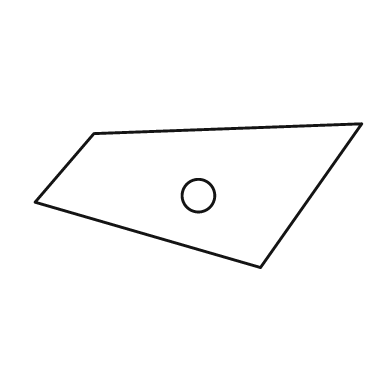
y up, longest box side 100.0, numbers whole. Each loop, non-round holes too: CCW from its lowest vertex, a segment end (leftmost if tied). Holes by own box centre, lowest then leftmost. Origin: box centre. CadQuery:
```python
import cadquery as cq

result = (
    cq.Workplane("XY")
    .moveTo(19.0, -22.0)
    .lineTo(50.0, 22.0)
    .lineTo(-32.0, 19.0)
    .lineTo(-50.0, -2.0)
    .close()
    .moveTo(0.0, 0.0)
    .circle(5.0)
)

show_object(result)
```